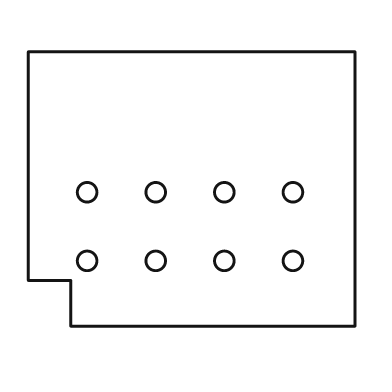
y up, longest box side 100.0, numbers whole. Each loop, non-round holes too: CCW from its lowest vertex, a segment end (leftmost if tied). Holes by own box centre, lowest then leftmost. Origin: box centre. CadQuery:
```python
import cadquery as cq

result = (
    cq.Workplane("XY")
    .moveTo(-37.0, -42.0)
    .lineTo(50.0, -42.0)
    .lineTo(50.0, 42.0)
    .lineTo(-50.0, 42.0)
    .lineTo(-50.0, -28.0)
    .lineTo(-37.0, -28.0)
    .close()
    .moveTo(-32.0, -22.0)
    .circle(3.0)
    .moveTo(-11.0, -22.0)
    .circle(3.0)
    .moveTo(10.0, -22.0)
    .circle(3.0)
    .moveTo(31.0, -22.0)
    .circle(3.0)
    .moveTo(-32.0, -1.0)
    .circle(3.0)
    .moveTo(-11.0, -1.0)
    .circle(3.0)
    .moveTo(10.0, -1.0)
    .circle(3.0)
    .moveTo(31.0, -1.0)
    .circle(3.0)
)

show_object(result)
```